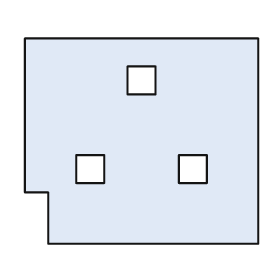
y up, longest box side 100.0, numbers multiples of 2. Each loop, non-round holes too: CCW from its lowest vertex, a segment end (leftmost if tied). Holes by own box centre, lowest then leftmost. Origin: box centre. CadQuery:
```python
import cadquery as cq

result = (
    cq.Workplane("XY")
    .moveTo(-40.0, -44.0)
    .lineTo(50.0, -44.0)
    .lineTo(50.0, 44.0)
    .lineTo(-50.0, 44.0)
    .lineTo(-50.0, -22.0)
    .lineTo(-40.0, -22.0)
    .close()
    .moveTo(-28.0, -18.0)
    .lineTo(-16.0, -18.0)
    .lineTo(-16.0, -6.0)
    .lineTo(-28.0, -6.0)
    .close()
    .moveTo(16.0, -18.0)
    .lineTo(28.0, -18.0)
    .lineTo(28.0, -6.0)
    .lineTo(16.0, -6.0)
    .close()
    .moveTo(-6.0, 20.0)
    .lineTo(6.0, 20.0)
    .lineTo(6.0, 32.0)
    .lineTo(-6.0, 32.0)
    .close()
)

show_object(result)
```